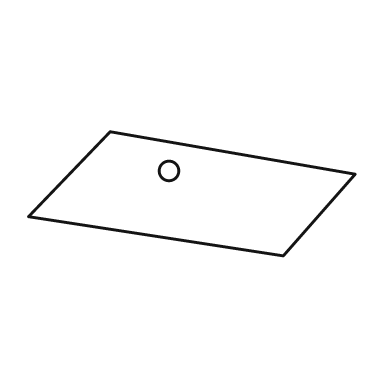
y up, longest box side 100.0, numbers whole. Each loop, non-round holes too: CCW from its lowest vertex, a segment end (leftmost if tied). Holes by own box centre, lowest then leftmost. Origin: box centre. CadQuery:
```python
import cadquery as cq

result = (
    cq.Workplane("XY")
    .moveTo(28.0, -19.0)
    .lineTo(50.0, 6.0)
    .lineTo(-25.0, 19.0)
    .lineTo(-50.0, -7.0)
    .close()
    .moveTo(-7.0, 7.0)
    .circle(3.0)
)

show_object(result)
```